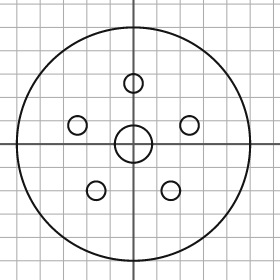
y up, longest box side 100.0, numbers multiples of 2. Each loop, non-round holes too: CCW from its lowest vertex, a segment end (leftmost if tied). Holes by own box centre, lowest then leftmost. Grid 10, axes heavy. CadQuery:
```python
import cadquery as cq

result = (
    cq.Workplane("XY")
    .moveTo(0.0, 0.0)
    .circle(50.0)
    .moveTo(-16.0, -20.0)
    .circle(4.0)
    .moveTo(16.0, -20.0)
    .circle(4.0)
    .moveTo(0.0, 0.0)
    .circle(8.0)
    .moveTo(-24.0, 8.0)
    .circle(4.0)
    .moveTo(24.0, 8.0)
    .circle(4.0)
    .moveTo(0.0, 26.0)
    .circle(4.0)
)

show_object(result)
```